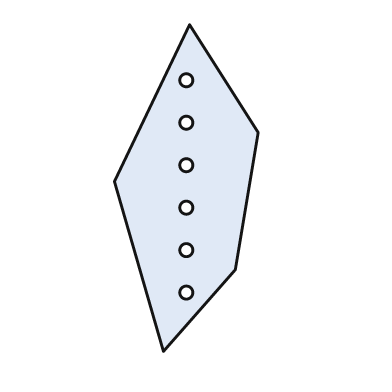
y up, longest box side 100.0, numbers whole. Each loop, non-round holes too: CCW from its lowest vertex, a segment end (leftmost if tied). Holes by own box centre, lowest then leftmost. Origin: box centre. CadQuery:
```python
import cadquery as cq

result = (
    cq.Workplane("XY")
    .moveTo(-7.0, -50.0)
    .lineTo(15.0, -25.0)
    .lineTo(22.0, 17.0)
    .lineTo(1.0, 50.0)
    .lineTo(-22.0, 2.0)
    .close()
    .moveTo(0.0, -32.0)
    .circle(2.0)
    .moveTo(0.0, -19.0)
    .circle(2.0)
    .moveTo(0.0, -6.0)
    .circle(2.0)
    .moveTo(0.0, 7.0)
    .circle(2.0)
    .moveTo(0.0, 20.0)
    .circle(2.0)
    .moveTo(0.0, 33.0)
    .circle(2.0)
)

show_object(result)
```